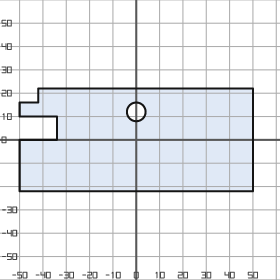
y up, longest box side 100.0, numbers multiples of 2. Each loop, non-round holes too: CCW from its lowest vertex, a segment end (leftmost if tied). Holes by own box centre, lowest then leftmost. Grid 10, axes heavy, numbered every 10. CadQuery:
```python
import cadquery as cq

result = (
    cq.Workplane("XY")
    .moveTo(-50.0, -22.0)
    .lineTo(50.0, -22.0)
    .lineTo(50.0, 22.0)
    .lineTo(-42.0, 22.0)
    .lineTo(-42.0, 16.0)
    .lineTo(-50.0, 16.0)
    .lineTo(-50.0, 10.0)
    .lineTo(-34.0, 10.0)
    .lineTo(-34.0, 0.0)
    .lineTo(-50.0, 0.0)
    .close()
    .moveTo(0.0, 12.0)
    .circle(4.0)
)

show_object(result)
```